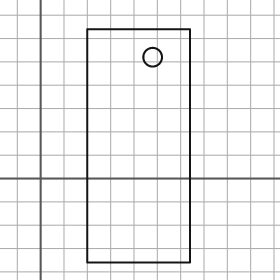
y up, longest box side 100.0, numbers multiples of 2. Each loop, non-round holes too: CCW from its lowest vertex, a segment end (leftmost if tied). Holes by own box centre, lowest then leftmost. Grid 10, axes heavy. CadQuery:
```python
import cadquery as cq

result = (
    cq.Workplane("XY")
    .moveTo(20.0, -36.0)
    .lineTo(64.0, -36.0)
    .lineTo(64.0, 64.0)
    .lineTo(20.0, 64.0)
    .close()
    .moveTo(48.0, 52.0)
    .circle(4.0)
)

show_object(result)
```